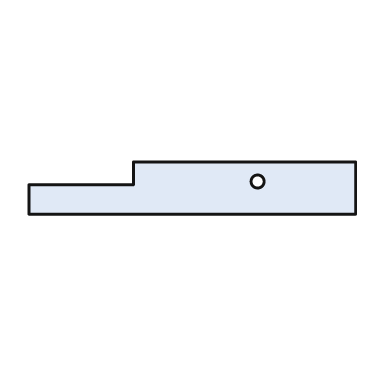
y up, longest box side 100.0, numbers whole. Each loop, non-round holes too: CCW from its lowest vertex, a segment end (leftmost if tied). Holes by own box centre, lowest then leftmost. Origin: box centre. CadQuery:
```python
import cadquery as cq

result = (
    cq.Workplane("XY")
    .moveTo(-50.0, -8.0)
    .lineTo(50.0, -8.0)
    .lineTo(50.0, 8.0)
    .lineTo(-18.0, 8.0)
    .lineTo(-18.0, 1.0)
    .lineTo(-50.0, 1.0)
    .close()
    .moveTo(20.0, 2.0)
    .circle(2.0)
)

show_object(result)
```